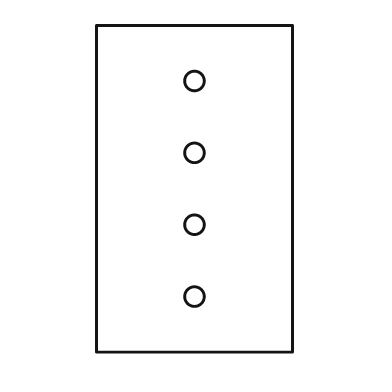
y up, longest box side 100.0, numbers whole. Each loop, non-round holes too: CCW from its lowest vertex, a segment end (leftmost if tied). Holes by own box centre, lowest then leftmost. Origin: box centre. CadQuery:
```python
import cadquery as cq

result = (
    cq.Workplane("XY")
    .moveTo(-30.0, -50.0)
    .lineTo(30.0, -50.0)
    .lineTo(30.0, 50.0)
    .lineTo(-30.0, 50.0)
    .close()
    .moveTo(0.0, -33.0)
    .circle(3.0)
    .moveTo(0.0, -11.0)
    .circle(3.0)
    .moveTo(0.0, 11.0)
    .circle(3.0)
    .moveTo(0.0, 33.0)
    .circle(3.0)
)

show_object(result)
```